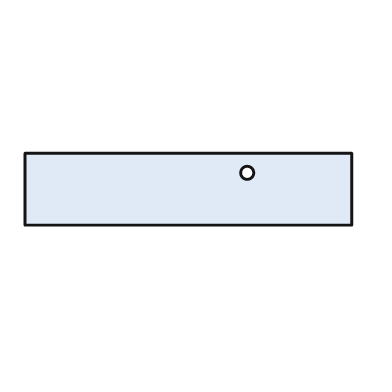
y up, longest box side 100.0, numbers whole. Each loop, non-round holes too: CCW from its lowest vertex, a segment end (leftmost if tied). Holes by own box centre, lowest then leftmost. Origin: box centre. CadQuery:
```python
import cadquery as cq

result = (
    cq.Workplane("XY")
    .moveTo(-50.0, -11.0)
    .lineTo(50.0, -11.0)
    .lineTo(50.0, 11.0)
    .lineTo(-50.0, 11.0)
    .close()
    .moveTo(18.0, 5.0)
    .circle(2.0)
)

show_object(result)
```